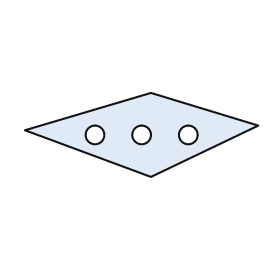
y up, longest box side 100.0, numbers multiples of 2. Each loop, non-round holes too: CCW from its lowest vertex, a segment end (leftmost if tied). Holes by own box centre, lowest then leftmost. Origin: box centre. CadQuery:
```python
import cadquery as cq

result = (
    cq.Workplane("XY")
    .moveTo(4.0, -18.0)
    .lineTo(50.0, 4.0)
    .lineTo(4.0, 18.0)
    .lineTo(-50.0, 2.0)
    .close()
    .moveTo(-20.0, 0.0)
    .circle(4.0)
    .moveTo(0.0, 0.0)
    .circle(4.0)
    .moveTo(20.0, 0.0)
    .circle(4.0)
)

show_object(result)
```